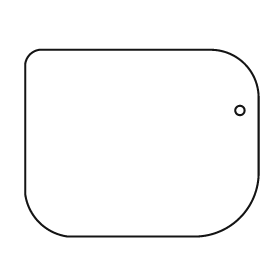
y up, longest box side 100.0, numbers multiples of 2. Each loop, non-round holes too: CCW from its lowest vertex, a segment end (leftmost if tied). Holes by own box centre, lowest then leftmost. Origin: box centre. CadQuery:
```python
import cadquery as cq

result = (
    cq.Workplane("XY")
    .moveTo(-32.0, -40.0)
    .lineTo(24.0, -40.0)
    .threePointArc((42.0, -32.0), (50.0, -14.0))
    .lineTo(50.0, 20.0)
    .threePointArc((44.0, 34.0), (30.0, 40.0))
    .lineTo(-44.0, 40.0)
    .threePointArc((-48.0, 38.0), (-50.0, 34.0))
    .lineTo(-50.0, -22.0)
    .threePointArc((-44.0, -34.0), (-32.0, -40.0))
    .close()
    .moveTo(42.0, 14.0)
    .circle(2.0)
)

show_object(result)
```